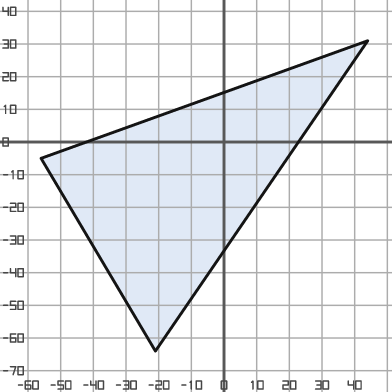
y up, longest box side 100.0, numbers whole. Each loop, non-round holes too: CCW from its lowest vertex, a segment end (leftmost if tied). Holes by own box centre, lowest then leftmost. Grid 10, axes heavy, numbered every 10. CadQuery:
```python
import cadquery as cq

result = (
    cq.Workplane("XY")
    .moveTo(-21.0, -64.0)
    .lineTo(44.0, 31.0)
    .lineTo(-56.0, -5.0)
    .close()
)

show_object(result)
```